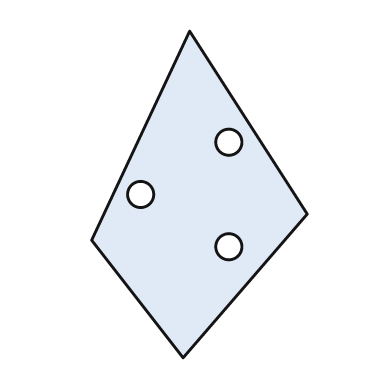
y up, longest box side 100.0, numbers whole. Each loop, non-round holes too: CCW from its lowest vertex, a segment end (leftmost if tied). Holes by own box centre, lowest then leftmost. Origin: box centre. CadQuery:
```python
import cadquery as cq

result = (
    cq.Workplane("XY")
    .moveTo(-5.0, -50.0)
    .lineTo(33.0, -6.0)
    .lineTo(-3.0, 50.0)
    .lineTo(-33.0, -14.0)
    .close()
    .moveTo(9.0, -16.0)
    .circle(4.0)
    .moveTo(-18.0, 0.0)
    .circle(4.0)
    .moveTo(9.0, 16.0)
    .circle(4.0)
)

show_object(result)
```